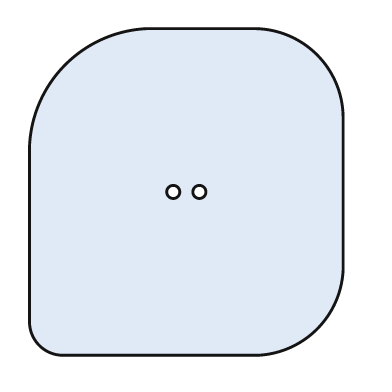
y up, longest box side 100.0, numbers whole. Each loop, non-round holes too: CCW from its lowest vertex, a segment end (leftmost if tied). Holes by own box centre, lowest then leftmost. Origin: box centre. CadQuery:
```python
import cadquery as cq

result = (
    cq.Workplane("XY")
    .moveTo(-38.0, -50.0)
    .lineTo(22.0, -50.0)
    .threePointArc((40.0, -42.0), (48.0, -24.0))
    .lineTo(48.0, 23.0)
    .threePointArc((40.0, 42.0), (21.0, 50.0))
    .lineTo(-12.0, 50.0)
    .threePointArc((-37.0, 39.0), (-48.0, 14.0))
    .lineTo(-48.0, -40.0)
    .threePointArc((-45.0, -47.0), (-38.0, -50.0))
    .close()
    .moveTo(-4.0, 0.0)
    .circle(2.0)
    .moveTo(4.0, 0.0)
    .circle(2.0)
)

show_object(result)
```